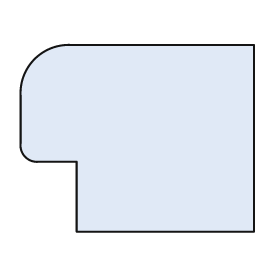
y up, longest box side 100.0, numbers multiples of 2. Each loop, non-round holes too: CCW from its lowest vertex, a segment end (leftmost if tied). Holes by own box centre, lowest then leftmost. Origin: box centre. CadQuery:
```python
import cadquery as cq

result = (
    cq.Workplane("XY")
    .moveTo(-26.0, -40.0)
    .lineTo(50.0, -40.0)
    .lineTo(50.0, 40.0)
    .lineTo(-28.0, 40.0)
    .threePointArc((-44.0, 34.0), (-50.0, 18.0))
    .lineTo(-50.0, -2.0)
    .threePointArc((-48.0, -8.0), (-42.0, -10.0))
    .lineTo(-26.0, -10.0)
    .close()
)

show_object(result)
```